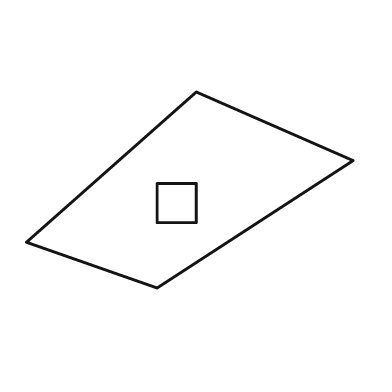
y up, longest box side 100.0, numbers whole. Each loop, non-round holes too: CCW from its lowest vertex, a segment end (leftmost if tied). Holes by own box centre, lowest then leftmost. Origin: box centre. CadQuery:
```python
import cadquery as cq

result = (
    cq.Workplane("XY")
    .moveTo(-10.0, -30.0)
    .lineTo(50.0, 9.0)
    .lineTo(2.0, 30.0)
    .lineTo(-50.0, -16.0)
    .close()
    .moveTo(-10.0, -10.0)
    .lineTo(2.0, -10.0)
    .lineTo(2.0, 2.0)
    .lineTo(-10.0, 2.0)
    .close()
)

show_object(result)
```